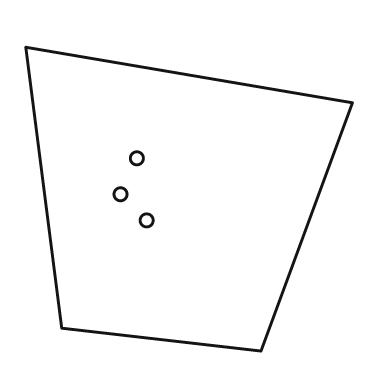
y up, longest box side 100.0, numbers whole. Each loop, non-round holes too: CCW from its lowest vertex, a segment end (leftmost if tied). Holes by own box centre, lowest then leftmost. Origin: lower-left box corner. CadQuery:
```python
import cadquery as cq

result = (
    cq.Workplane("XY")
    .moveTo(72.0, 0.0)
    .lineTo(100.0, 76.0)
    .lineTo(0.0, 93.0)
    .lineTo(11.0, 7.0)
    .close()
    .moveTo(37.0, 40.0)
    .circle(2.0)
    .moveTo(29.0, 48.0)
    .circle(2.0)
    .moveTo(34.0, 59.0)
    .circle(2.0)
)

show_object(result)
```